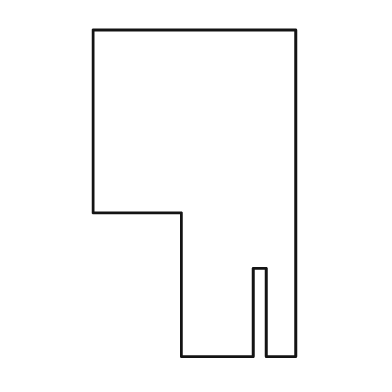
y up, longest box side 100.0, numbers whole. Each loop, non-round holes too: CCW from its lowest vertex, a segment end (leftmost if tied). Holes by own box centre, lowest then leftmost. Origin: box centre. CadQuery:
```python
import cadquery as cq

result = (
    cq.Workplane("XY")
    .moveTo(-4.0, -50.0)
    .lineTo(18.0, -50.0)
    .lineTo(18.0, -23.0)
    .lineTo(22.0, -23.0)
    .lineTo(22.0, -50.0)
    .lineTo(31.0, -50.0)
    .lineTo(31.0, 50.0)
    .lineTo(-31.0, 50.0)
    .lineTo(-31.0, -6.0)
    .lineTo(-4.0, -6.0)
    .close()
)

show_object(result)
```